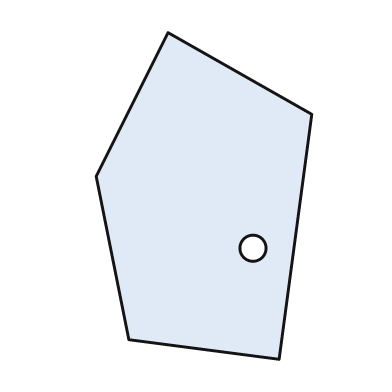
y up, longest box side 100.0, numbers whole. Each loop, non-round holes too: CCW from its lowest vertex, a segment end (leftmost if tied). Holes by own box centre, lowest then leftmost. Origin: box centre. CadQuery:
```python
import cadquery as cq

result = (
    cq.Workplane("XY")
    .moveTo(23.0, -50.0)
    .lineTo(33.0, 25.0)
    .lineTo(-11.0, 50.0)
    .lineTo(-33.0, 6.0)
    .lineTo(-23.0, -44.0)
    .close()
    .moveTo(15.0, -16.0)
    .circle(4.0)
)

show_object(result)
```